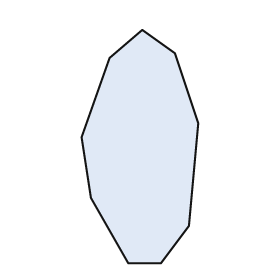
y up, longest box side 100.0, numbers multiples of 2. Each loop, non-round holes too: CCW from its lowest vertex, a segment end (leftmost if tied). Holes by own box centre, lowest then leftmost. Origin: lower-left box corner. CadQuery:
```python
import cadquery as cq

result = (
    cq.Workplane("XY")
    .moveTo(20.0, 0.0)
    .lineTo(34.0, 0.0)
    .lineTo(46.0, 16.0)
    .lineTo(50.0, 60.0)
    .lineTo(40.0, 90.0)
    .lineTo(26.0, 100.0)
    .lineTo(12.0, 88.0)
    .lineTo(0.0, 54.0)
    .lineTo(4.0, 28.0)
    .close()
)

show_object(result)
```